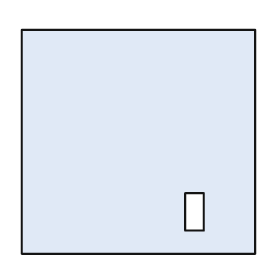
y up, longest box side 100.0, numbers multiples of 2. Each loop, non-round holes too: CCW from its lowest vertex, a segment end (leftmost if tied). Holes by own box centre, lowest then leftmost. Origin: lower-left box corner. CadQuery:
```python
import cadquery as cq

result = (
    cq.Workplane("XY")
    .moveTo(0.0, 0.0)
    .lineTo(100.0, 0.0)
    .lineTo(100.0, 96.0)
    .lineTo(0.0, 96.0)
    .close()
    .moveTo(70.0, 10.0)
    .lineTo(78.0, 10.0)
    .lineTo(78.0, 26.0)
    .lineTo(70.0, 26.0)
    .close()
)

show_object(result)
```